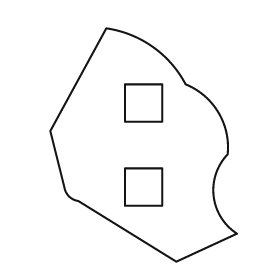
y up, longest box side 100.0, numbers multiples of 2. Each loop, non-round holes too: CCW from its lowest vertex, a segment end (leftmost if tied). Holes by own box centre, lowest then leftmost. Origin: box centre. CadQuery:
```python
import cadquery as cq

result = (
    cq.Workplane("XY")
    .moveTo(14.0, -50.0)
    .lineTo(40.0, -38.0)
    .threePointArc((30.0, -22.0), (36.0, -4.0))
    .threePointArc((32.0, 14.0), (18.0, 26.0))
    .threePointArc((4.0, 42.0), (-16.0, 50.0))
    .lineTo(-40.0, 6.0)
    .lineTo(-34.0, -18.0)
    .threePointArc((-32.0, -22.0), (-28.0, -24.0))
    .close()
    .moveTo(-8.0, -26.0)
    .lineTo(8.0, -26.0)
    .lineTo(8.0, -10.0)
    .lineTo(-8.0, -10.0)
    .close()
    .moveTo(-8.0, 10.0)
    .lineTo(8.0, 10.0)
    .lineTo(8.0, 26.0)
    .lineTo(-8.0, 26.0)
    .close()
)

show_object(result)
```